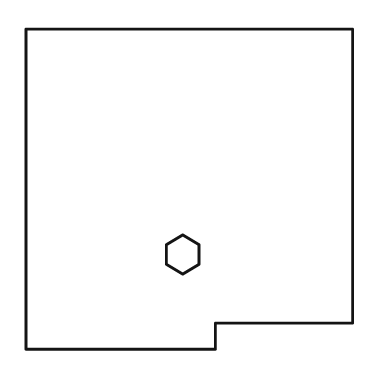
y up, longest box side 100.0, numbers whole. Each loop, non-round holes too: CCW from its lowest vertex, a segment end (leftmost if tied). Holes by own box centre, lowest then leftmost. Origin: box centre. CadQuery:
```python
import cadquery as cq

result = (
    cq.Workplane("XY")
    .moveTo(-50.0, -49.0)
    .lineTo(8.0, -49.0)
    .lineTo(8.0, -41.0)
    .lineTo(50.0, -41.0)
    .lineTo(50.0, 49.0)
    .lineTo(-50.0, 49.0)
    .close()
    .moveTo(-2.0, -26.0)
    .lineTo(3.0, -23.0)
    .lineTo(3.0, -17.0)
    .lineTo(-2.0, -14.0)
    .lineTo(-7.0, -17.0)
    .lineTo(-7.0, -23.0)
    .close()
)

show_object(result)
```